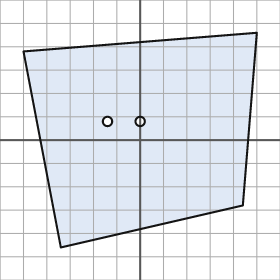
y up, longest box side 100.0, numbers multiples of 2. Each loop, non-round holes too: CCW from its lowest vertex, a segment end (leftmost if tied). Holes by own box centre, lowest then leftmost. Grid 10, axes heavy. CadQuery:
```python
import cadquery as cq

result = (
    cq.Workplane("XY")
    .moveTo(-34.0, -46.0)
    .lineTo(44.0, -28.0)
    .lineTo(50.0, 46.0)
    .lineTo(-50.0, 38.0)
    .close()
    .moveTo(-14.0, 8.0)
    .circle(2.0)
    .moveTo(0.0, 8.0)
    .circle(2.0)
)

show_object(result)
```